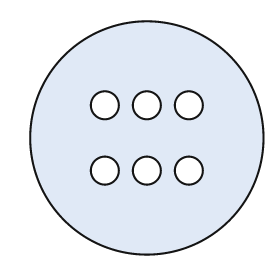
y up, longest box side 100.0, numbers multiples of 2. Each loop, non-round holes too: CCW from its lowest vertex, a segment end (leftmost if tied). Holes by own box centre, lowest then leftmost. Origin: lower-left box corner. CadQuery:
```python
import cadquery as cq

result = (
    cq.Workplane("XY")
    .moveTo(50.0, 50.0)
    .circle(50.0)
    .moveTo(32.0, 36.0)
    .circle(6.0)
    .moveTo(50.0, 36.0)
    .circle(6.0)
    .moveTo(68.0, 36.0)
    .circle(6.0)
    .moveTo(32.0, 64.0)
    .circle(6.0)
    .moveTo(50.0, 64.0)
    .circle(6.0)
    .moveTo(68.0, 64.0)
    .circle(6.0)
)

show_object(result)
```